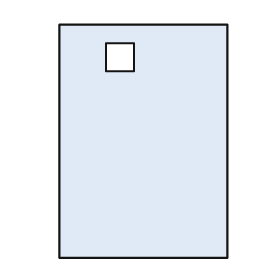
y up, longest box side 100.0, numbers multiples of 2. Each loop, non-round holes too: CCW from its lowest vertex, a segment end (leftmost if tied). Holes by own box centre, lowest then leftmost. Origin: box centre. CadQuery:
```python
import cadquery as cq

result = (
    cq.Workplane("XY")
    .moveTo(-36.0, -50.0)
    .lineTo(36.0, -50.0)
    .lineTo(36.0, 50.0)
    .lineTo(-36.0, 50.0)
    .close()
    .moveTo(-16.0, 30.0)
    .lineTo(-4.0, 30.0)
    .lineTo(-4.0, 42.0)
    .lineTo(-16.0, 42.0)
    .close()
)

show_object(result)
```